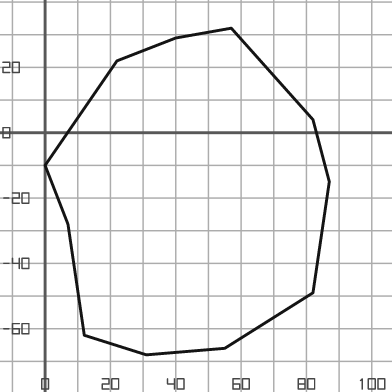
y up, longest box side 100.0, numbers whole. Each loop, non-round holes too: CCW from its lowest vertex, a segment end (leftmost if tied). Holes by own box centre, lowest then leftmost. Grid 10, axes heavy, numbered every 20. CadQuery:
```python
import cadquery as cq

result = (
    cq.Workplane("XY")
    .moveTo(31.0, -68.0)
    .lineTo(55.0, -66.0)
    .lineTo(82.0, -49.0)
    .lineTo(87.0, -15.0)
    .lineTo(82.0, 4.0)
    .lineTo(57.0, 32.0)
    .lineTo(40.0, 29.0)
    .lineTo(22.0, 22.0)
    .lineTo(0.0, -10.0)
    .lineTo(7.0, -28.0)
    .lineTo(12.0, -62.0)
    .close()
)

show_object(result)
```